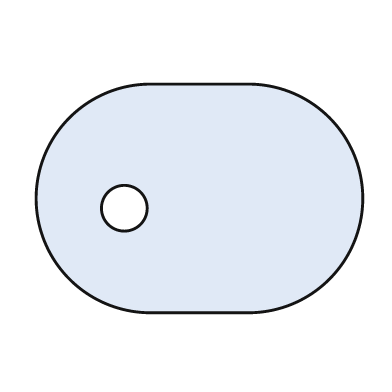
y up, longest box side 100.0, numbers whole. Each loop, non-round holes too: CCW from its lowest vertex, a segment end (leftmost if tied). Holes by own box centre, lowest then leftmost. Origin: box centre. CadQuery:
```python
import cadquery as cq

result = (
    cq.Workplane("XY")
    .moveTo(-15.0, -35.0)
    .lineTo(15.0, -35.0)
    .threePointArc((50.0, 0.0), (15.0, 35.0))
    .lineTo(-15.0, 35.0)
    .threePointArc((-50.0, 0.0), (-15.0, -35.0))
    .close()
    .moveTo(-23.0, -3.0)
    .circle(7.0)
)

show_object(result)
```